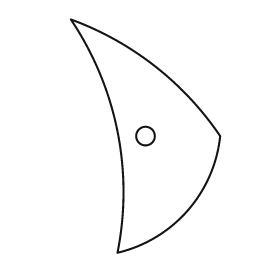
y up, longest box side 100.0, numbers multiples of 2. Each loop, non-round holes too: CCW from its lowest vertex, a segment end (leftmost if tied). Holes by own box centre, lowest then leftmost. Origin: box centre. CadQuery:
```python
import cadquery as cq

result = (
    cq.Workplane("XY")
    .moveTo(-12.0, -50.0)
    .threePointArc((18.0, -32.0), (32.0, 0.0))
    .threePointArc((4.0, 30.0), (-32.0, 50.0))
    .threePointArc((-12.0, 2.0), (-12.0, -50.0))
    .close()
    .moveTo(0.0, 0.0)
    .circle(4.0)
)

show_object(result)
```